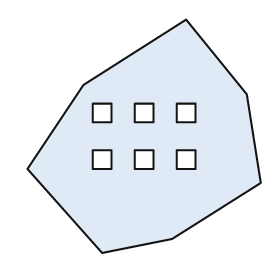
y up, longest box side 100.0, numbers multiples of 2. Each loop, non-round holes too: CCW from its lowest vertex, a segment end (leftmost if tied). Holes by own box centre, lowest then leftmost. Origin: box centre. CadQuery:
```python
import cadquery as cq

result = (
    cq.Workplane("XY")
    .moveTo(-18.0, -50.0)
    .lineTo(12.0, -44.0)
    .lineTo(50.0, -20.0)
    .lineTo(44.0, 18.0)
    .lineTo(18.0, 50.0)
    .lineTo(-26.0, 22.0)
    .lineTo(-50.0, -14.0)
    .close()
    .moveTo(-22.0, -14.0)
    .lineTo(-14.0, -14.0)
    .lineTo(-14.0, -6.0)
    .lineTo(-22.0, -6.0)
    .close()
    .moveTo(-4.0, -14.0)
    .lineTo(4.0, -14.0)
    .lineTo(4.0, -6.0)
    .lineTo(-4.0, -6.0)
    .close()
    .moveTo(14.0, -14.0)
    .lineTo(22.0, -14.0)
    .lineTo(22.0, -6.0)
    .lineTo(14.0, -6.0)
    .close()
    .moveTo(-22.0, 6.0)
    .lineTo(-14.0, 6.0)
    .lineTo(-14.0, 14.0)
    .lineTo(-22.0, 14.0)
    .close()
    .moveTo(-4.0, 6.0)
    .lineTo(4.0, 6.0)
    .lineTo(4.0, 14.0)
    .lineTo(-4.0, 14.0)
    .close()
    .moveTo(14.0, 6.0)
    .lineTo(22.0, 6.0)
    .lineTo(22.0, 14.0)
    .lineTo(14.0, 14.0)
    .close()
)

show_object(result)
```